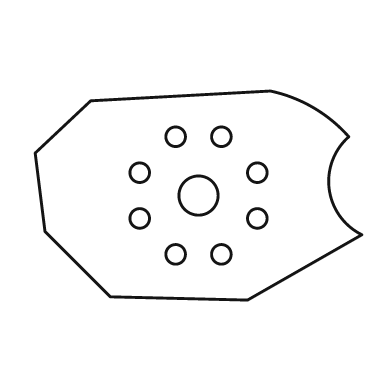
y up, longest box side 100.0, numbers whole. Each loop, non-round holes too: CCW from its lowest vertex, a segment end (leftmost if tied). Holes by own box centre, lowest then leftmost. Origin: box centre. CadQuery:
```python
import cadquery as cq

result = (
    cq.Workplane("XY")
    .moveTo(15.0, -32.0)
    .lineTo(50.0, -12.0)
    .threePointArc((40.0, 2.0), (46.0, 18.0))
    .threePointArc((35.0, 27.0), (22.0, 32.0))
    .lineTo(-33.0, 29.0)
    .lineTo(-50.0, 13.0)
    .lineTo(-47.0, -11.0)
    .lineTo(-27.0, -31.0)
    .close()
    .moveTo(-7.0, -18.0)
    .circle(3.0)
    .moveTo(7.0, -18.0)
    .circle(3.0)
    .moveTo(-18.0, -7.0)
    .circle(3.0)
    .moveTo(18.0, -7.0)
    .circle(3.0)
    .moveTo(0.0, 0.0)
    .circle(6.0)
    .moveTo(-18.0, 7.0)
    .circle(3.0)
    .moveTo(18.0, 7.0)
    .circle(3.0)
    .moveTo(-7.0, 18.0)
    .circle(3.0)
    .moveTo(7.0, 18.0)
    .circle(3.0)
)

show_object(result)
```